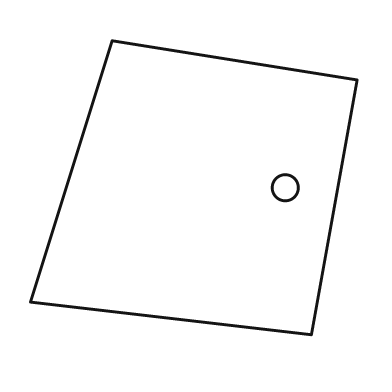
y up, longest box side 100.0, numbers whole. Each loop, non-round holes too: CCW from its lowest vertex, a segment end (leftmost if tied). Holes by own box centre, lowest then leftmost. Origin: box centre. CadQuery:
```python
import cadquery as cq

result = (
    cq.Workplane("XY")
    .moveTo(36.0, -45.0)
    .lineTo(50.0, 33.0)
    .lineTo(-25.0, 45.0)
    .lineTo(-50.0, -35.0)
    .close()
    .moveTo(28.0, 0.0)
    .circle(4.0)
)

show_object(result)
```